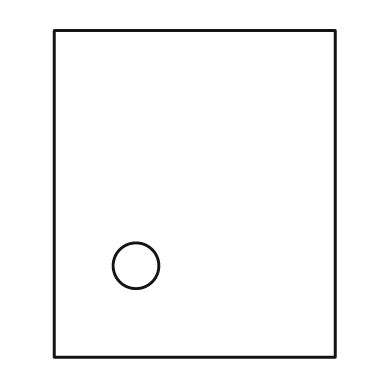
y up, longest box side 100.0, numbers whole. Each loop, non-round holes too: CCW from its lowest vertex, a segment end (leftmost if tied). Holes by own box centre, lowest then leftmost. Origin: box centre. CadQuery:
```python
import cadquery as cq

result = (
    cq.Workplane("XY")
    .moveTo(-43.0, -50.0)
    .lineTo(43.0, -50.0)
    .lineTo(43.0, 50.0)
    .lineTo(-43.0, 50.0)
    .close()
    .moveTo(-18.0, -22.0)
    .circle(7.0)
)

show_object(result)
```